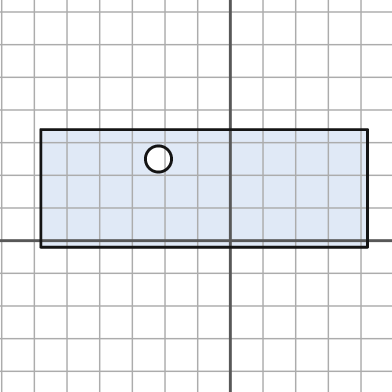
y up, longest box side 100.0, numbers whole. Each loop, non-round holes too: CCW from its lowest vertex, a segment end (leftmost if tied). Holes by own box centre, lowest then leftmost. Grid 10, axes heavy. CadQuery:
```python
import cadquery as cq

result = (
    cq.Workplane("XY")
    .moveTo(-58.0, -2.0)
    .lineTo(42.0, -2.0)
    .lineTo(42.0, 34.0)
    .lineTo(-58.0, 34.0)
    .close()
    .moveTo(-22.0, 25.0)
    .circle(4.0)
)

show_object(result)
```